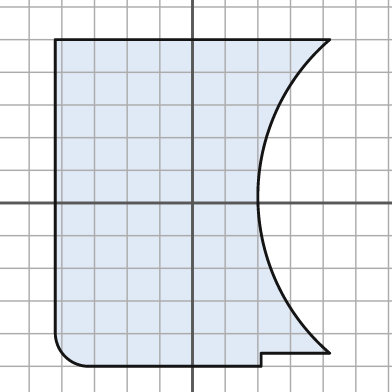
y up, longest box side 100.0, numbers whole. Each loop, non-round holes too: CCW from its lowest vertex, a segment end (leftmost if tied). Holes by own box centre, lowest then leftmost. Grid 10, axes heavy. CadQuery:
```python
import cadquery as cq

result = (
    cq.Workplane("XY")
    .moveTo(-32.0, -50.0)
    .lineTo(21.0, -50.0)
    .lineTo(21.0, -46.0)
    .lineTo(42.0, -46.0)
    .threePointArc((20.0, 2.0), (42.0, 50.0))
    .lineTo(-42.0, 50.0)
    .lineTo(-42.0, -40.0)
    .threePointArc((-39.0, -47.0), (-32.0, -50.0))
    .close()
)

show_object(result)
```